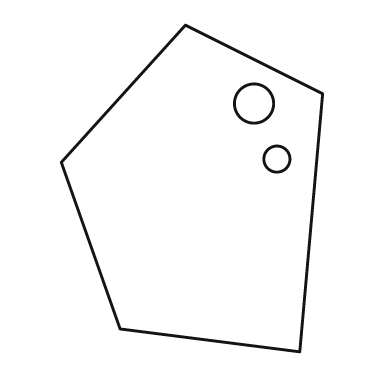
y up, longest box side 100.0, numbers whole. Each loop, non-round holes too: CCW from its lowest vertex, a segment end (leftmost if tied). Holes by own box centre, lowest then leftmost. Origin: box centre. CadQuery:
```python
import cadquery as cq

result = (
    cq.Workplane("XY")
    .moveTo(33.0, -50.0)
    .lineTo(40.0, 29.0)
    .lineTo(-2.0, 50.0)
    .lineTo(-40.0, 8.0)
    .lineTo(-22.0, -43.0)
    .close()
    .moveTo(26.0, 9.0)
    .circle(4.0)
    .moveTo(19.0, 26.0)
    .circle(6.0)
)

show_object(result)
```